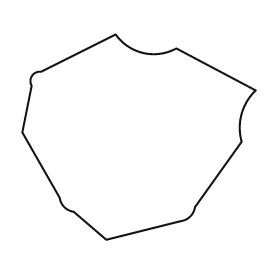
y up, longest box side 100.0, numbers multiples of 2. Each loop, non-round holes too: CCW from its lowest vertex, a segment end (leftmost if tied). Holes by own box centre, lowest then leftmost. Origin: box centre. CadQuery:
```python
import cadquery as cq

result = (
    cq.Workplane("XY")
    .moveTo(-14.0, -44.0)
    .lineTo(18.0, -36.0)
    .threePointArc((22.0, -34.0), (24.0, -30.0))
    .lineTo(44.0, -2.0)
    .threePointArc((44.0, 10.0), (50.0, 20.0))
    .lineTo(16.0, 38.0)
    .threePointArc((2.0, 36.0), (-10.0, 44.0))
    .lineTo(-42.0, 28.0)
    .threePointArc((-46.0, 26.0), (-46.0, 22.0))
    .lineTo(-50.0, 2.0)
    .lineTo(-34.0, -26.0)
    .threePointArc((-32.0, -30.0), (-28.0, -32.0))
    .close()
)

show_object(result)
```